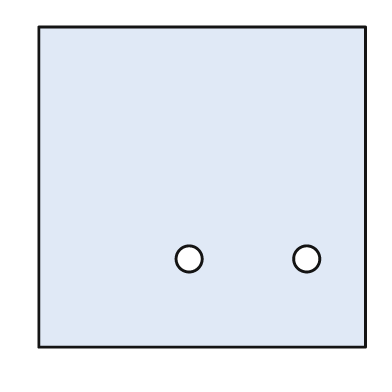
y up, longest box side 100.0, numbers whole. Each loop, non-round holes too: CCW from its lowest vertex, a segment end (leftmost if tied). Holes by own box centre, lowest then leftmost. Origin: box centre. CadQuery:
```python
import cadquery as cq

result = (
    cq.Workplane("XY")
    .moveTo(-50.0, -49.0)
    .lineTo(50.0, -49.0)
    .lineTo(50.0, 49.0)
    .lineTo(-50.0, 49.0)
    .close()
    .moveTo(-4.0, -22.0)
    .circle(4.0)
    .moveTo(32.0, -22.0)
    .circle(4.0)
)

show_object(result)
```